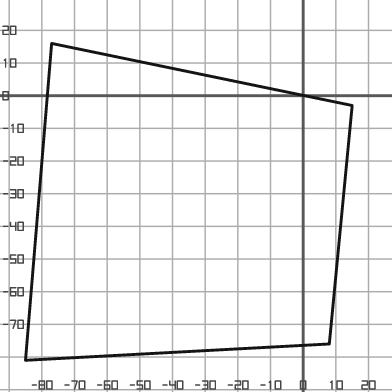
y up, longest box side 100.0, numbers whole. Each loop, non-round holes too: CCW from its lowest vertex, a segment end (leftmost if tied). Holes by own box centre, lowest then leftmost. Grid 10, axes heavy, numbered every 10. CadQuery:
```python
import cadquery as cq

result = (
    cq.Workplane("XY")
    .moveTo(-85.0, -81.0)
    .lineTo(8.0, -76.0)
    .lineTo(15.0, -3.0)
    .lineTo(-77.0, 16.0)
    .close()
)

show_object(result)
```